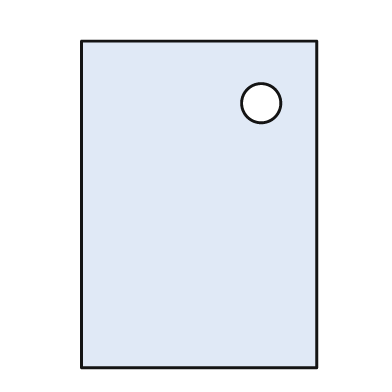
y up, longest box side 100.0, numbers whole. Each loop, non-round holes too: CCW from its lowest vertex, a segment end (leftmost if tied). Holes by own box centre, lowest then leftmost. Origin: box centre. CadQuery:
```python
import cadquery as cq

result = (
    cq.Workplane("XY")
    .moveTo(-36.0, -50.0)
    .lineTo(36.0, -50.0)
    .lineTo(36.0, 50.0)
    .lineTo(-36.0, 50.0)
    .close()
    .moveTo(19.0, 31.0)
    .circle(6.0)
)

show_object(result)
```